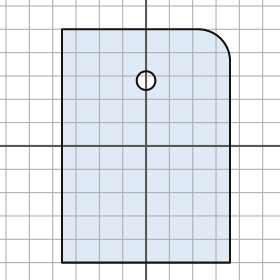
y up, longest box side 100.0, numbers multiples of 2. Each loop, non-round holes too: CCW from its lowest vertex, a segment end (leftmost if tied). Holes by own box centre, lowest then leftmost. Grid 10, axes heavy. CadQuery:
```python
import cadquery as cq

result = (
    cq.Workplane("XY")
    .moveTo(-36.0, -50.0)
    .lineTo(36.0, -50.0)
    .lineTo(36.0, 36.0)
    .threePointArc((32.0, 46.0), (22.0, 50.0))
    .lineTo(-36.0, 50.0)
    .close()
    .moveTo(0.0, 28.0)
    .circle(4.0)
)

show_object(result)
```